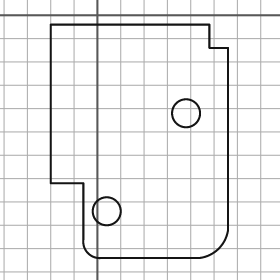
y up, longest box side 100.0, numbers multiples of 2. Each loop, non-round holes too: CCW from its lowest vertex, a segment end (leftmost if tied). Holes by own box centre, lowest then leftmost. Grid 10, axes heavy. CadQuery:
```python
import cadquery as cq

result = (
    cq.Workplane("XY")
    .moveTo(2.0, -104.0)
    .lineTo(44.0, -104.0)
    .threePointArc((52.0, -100.0), (56.0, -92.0))
    .lineTo(56.0, -14.0)
    .lineTo(48.0, -14.0)
    .lineTo(48.0, -4.0)
    .lineTo(-20.0, -4.0)
    .lineTo(-20.0, -72.0)
    .lineTo(-6.0, -72.0)
    .lineTo(-6.0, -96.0)
    .threePointArc((-4.0, -102.0), (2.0, -104.0))
    .close()
    .moveTo(4.0, -84.0)
    .circle(6.0)
    .moveTo(38.0, -42.0)
    .circle(6.0)
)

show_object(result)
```